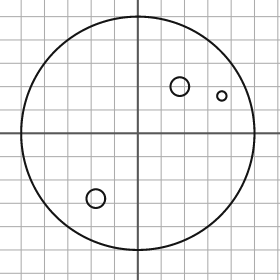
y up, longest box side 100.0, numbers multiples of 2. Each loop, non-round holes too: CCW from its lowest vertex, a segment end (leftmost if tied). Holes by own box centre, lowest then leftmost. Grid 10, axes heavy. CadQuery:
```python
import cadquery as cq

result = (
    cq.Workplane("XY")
    .moveTo(0.0, 0.0)
    .circle(50.0)
    .moveTo(-18.0, -28.0)
    .circle(4.0)
    .moveTo(36.0, 16.0)
    .circle(2.0)
    .moveTo(18.0, 20.0)
    .circle(4.0)
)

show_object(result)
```